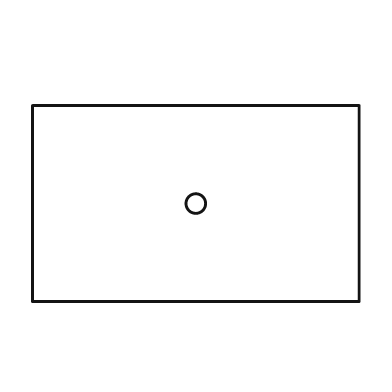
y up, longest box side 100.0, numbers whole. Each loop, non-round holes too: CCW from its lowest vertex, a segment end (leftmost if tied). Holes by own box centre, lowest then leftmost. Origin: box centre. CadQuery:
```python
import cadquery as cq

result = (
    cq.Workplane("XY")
    .moveTo(-50.0, -30.0)
    .lineTo(50.0, -30.0)
    .lineTo(50.0, 30.0)
    .lineTo(-50.0, 30.0)
    .close()
    .moveTo(0.0, 0.0)
    .circle(3.0)
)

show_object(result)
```